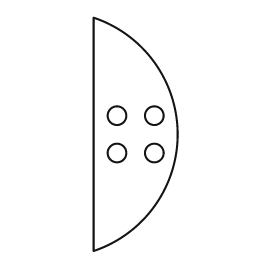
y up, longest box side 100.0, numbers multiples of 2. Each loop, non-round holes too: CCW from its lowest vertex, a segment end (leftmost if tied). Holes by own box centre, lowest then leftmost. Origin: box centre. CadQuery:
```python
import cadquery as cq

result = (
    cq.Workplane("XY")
    .moveTo(-18.0, -50.0)
    .threePointArc((18.0, 0.0), (-18.0, 50.0))
    .close()
    .moveTo(-8.0, -8.0)
    .circle(4.0)
    .moveTo(8.0, -8.0)
    .circle(4.0)
    .moveTo(-8.0, 8.0)
    .circle(4.0)
    .moveTo(8.0, 8.0)
    .circle(4.0)
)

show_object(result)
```